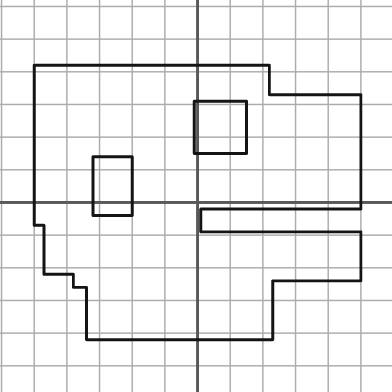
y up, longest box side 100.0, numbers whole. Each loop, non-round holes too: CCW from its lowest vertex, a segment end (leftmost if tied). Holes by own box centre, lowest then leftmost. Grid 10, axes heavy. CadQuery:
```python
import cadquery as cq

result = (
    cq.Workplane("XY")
    .moveTo(-34.0, -42.0)
    .lineTo(23.0, -42.0)
    .lineTo(23.0, -24.0)
    .lineTo(50.0, -24.0)
    .lineTo(50.0, -9.0)
    .lineTo(1.0, -9.0)
    .lineTo(1.0, -2.0)
    .lineTo(50.0, -2.0)
    .lineTo(50.0, 33.0)
    .lineTo(22.0, 33.0)
    .lineTo(22.0, 42.0)
    .lineTo(-50.0, 42.0)
    .lineTo(-50.0, -7.0)
    .lineTo(-47.0, -7.0)
    .lineTo(-47.0, -22.0)
    .lineTo(-38.0, -22.0)
    .lineTo(-38.0, -26.0)
    .lineTo(-34.0, -26.0)
    .close()
    .moveTo(-32.0, -4.0)
    .lineTo(-20.0, -4.0)
    .lineTo(-20.0, 14.0)
    .lineTo(-32.0, 14.0)
    .close()
    .moveTo(-1.0, 15.0)
    .lineTo(15.0, 15.0)
    .lineTo(15.0, 31.0)
    .lineTo(-1.0, 31.0)
    .close()
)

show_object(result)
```